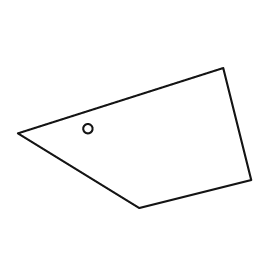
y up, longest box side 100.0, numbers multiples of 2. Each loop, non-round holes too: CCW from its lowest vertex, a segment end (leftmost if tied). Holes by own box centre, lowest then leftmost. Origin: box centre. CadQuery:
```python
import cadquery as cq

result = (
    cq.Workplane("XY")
    .moveTo(2.0, -30.0)
    .lineTo(50.0, -18.0)
    .lineTo(38.0, 30.0)
    .lineTo(-50.0, 2.0)
    .close()
    .moveTo(-20.0, 4.0)
    .circle(2.0)
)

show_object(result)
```